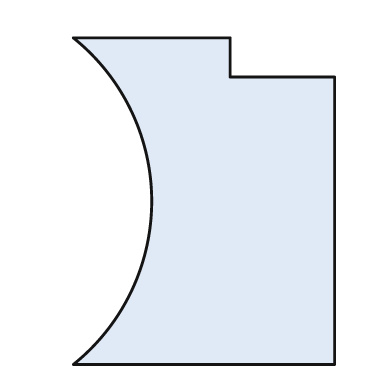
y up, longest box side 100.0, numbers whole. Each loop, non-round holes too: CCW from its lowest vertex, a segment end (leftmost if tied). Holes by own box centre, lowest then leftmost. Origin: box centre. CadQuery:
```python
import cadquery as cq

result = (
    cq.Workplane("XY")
    .moveTo(-40.0, -50.0)
    .lineTo(40.0, -50.0)
    .lineTo(40.0, 38.0)
    .lineTo(8.0, 38.0)
    .lineTo(8.0, 50.0)
    .lineTo(-40.0, 50.0)
    .threePointArc((-16.0, 0.0), (-40.0, -50.0))
    .close()
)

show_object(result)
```